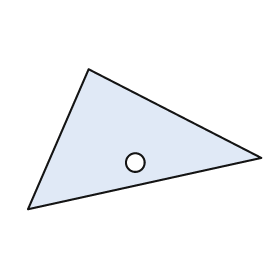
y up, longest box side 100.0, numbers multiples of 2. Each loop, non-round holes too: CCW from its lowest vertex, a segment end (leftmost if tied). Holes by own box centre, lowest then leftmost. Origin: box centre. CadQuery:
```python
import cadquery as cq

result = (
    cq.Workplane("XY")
    .moveTo(-50.0, -30.0)
    .lineTo(50.0, -8.0)
    .lineTo(-24.0, 30.0)
    .close()
    .moveTo(-4.0, -10.0)
    .circle(4.0)
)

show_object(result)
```